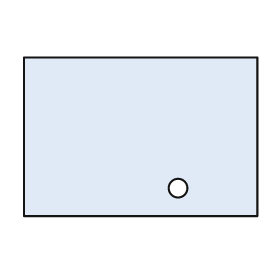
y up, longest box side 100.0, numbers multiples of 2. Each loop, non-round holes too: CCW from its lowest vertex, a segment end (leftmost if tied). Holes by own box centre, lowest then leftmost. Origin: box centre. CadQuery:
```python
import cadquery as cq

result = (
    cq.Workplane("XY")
    .moveTo(-50.0, -34.0)
    .lineTo(50.0, -34.0)
    .lineTo(50.0, 34.0)
    .lineTo(-50.0, 34.0)
    .close()
    .moveTo(16.0, -22.0)
    .circle(4.0)
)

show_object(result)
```